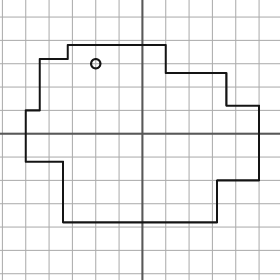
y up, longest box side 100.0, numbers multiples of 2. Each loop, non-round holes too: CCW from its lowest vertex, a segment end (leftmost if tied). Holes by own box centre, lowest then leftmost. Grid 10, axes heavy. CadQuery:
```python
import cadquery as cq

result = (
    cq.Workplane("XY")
    .moveTo(-34.0, -38.0)
    .lineTo(32.0, -38.0)
    .lineTo(32.0, -20.0)
    .lineTo(50.0, -20.0)
    .lineTo(50.0, 12.0)
    .lineTo(36.0, 12.0)
    .lineTo(36.0, 26.0)
    .lineTo(10.0, 26.0)
    .lineTo(10.0, 38.0)
    .lineTo(-32.0, 38.0)
    .lineTo(-32.0, 32.0)
    .lineTo(-44.0, 32.0)
    .lineTo(-44.0, 10.0)
    .lineTo(-50.0, 10.0)
    .lineTo(-50.0, -12.0)
    .lineTo(-34.0, -12.0)
    .close()
    .moveTo(-20.0, 30.0)
    .circle(2.0)
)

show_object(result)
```